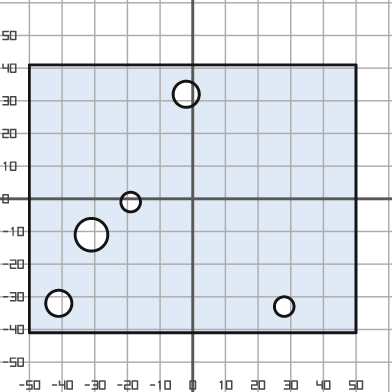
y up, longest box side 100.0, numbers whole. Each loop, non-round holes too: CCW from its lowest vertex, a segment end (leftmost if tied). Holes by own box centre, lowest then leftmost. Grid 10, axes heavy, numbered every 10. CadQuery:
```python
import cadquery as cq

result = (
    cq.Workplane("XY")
    .moveTo(-50.0, -41.0)
    .lineTo(50.0, -41.0)
    .lineTo(50.0, 41.0)
    .lineTo(-50.0, 41.0)
    .close()
    .moveTo(28.0, -33.0)
    .circle(3.0)
    .moveTo(-41.0, -32.0)
    .circle(4.0)
    .moveTo(-31.0, -11.0)
    .circle(5.0)
    .moveTo(-19.0, -1.0)
    .circle(3.0)
    .moveTo(-2.0, 32.0)
    .circle(4.0)
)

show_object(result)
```